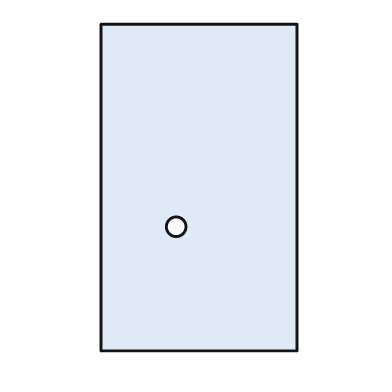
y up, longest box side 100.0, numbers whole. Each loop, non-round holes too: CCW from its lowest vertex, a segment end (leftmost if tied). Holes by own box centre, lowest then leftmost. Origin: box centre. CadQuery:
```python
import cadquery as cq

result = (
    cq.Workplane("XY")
    .moveTo(-30.0, -50.0)
    .lineTo(30.0, -50.0)
    .lineTo(30.0, 50.0)
    .lineTo(-30.0, 50.0)
    .close()
    .moveTo(-7.0, -12.0)
    .circle(3.0)
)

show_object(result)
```